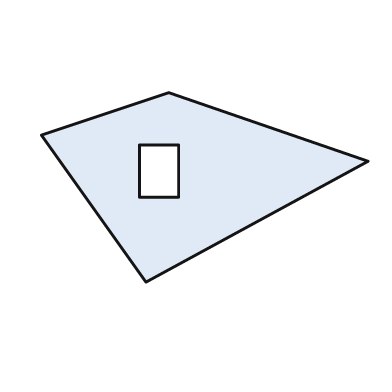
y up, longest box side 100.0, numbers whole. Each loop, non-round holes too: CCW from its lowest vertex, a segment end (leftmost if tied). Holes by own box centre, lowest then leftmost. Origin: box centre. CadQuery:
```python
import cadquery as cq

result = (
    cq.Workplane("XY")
    .moveTo(-18.0, -29.0)
    .lineTo(50.0, 8.0)
    .lineTo(-11.0, 29.0)
    .lineTo(-50.0, 16.0)
    .close()
    .moveTo(-20.0, -3.0)
    .lineTo(-8.0, -3.0)
    .lineTo(-8.0, 13.0)
    .lineTo(-20.0, 13.0)
    .close()
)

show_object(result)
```